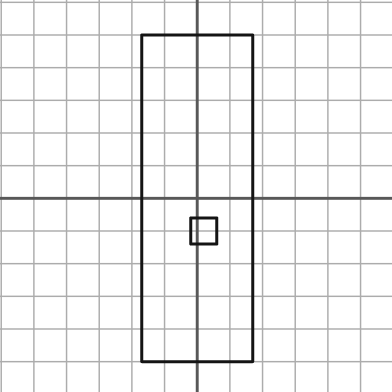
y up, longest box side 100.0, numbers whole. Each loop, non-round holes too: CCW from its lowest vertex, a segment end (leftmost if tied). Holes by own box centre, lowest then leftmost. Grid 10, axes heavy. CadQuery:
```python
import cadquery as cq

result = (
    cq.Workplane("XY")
    .moveTo(-17.0, -50.0)
    .lineTo(17.0, -50.0)
    .lineTo(17.0, 50.0)
    .lineTo(-17.0, 50.0)
    .close()
    .moveTo(-2.0, -14.0)
    .lineTo(6.0, -14.0)
    .lineTo(6.0, -6.0)
    .lineTo(-2.0, -6.0)
    .close()
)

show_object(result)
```